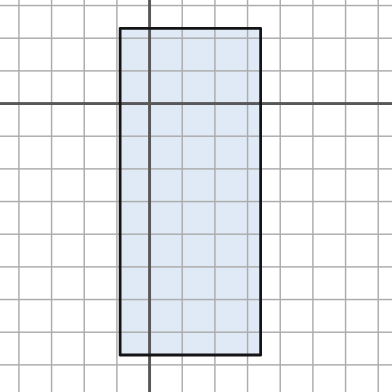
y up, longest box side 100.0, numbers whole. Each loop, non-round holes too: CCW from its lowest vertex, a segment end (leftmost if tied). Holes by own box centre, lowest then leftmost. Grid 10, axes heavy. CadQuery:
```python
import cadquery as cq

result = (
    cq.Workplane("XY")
    .moveTo(-9.0, -77.0)
    .lineTo(34.0, -77.0)
    .lineTo(34.0, 23.0)
    .lineTo(-9.0, 23.0)
    .close()
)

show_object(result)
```